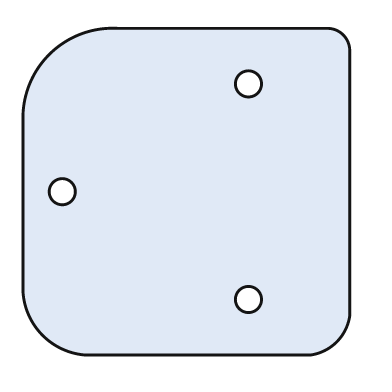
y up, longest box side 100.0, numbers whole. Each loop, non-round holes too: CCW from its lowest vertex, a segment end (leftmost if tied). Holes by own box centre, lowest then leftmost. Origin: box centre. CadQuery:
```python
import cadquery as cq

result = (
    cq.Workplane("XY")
    .moveTo(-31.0, -50.0)
    .lineTo(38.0, -50.0)
    .threePointArc((46.0, -46.0), (50.0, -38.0))
    .lineTo(50.0, 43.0)
    .threePointArc((48.0, 48.0), (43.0, 50.0))
    .lineTo(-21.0, 50.0)
    .threePointArc((-42.0, 42.0), (-50.0, 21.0))
    .lineTo(-50.0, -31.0)
    .threePointArc((-44.0, -44.0), (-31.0, -50.0))
    .close()
    .moveTo(19.0, -33.0)
    .circle(4.0)
    .moveTo(-38.0, 0.0)
    .circle(4.0)
    .moveTo(19.0, 33.0)
    .circle(4.0)
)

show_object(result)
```